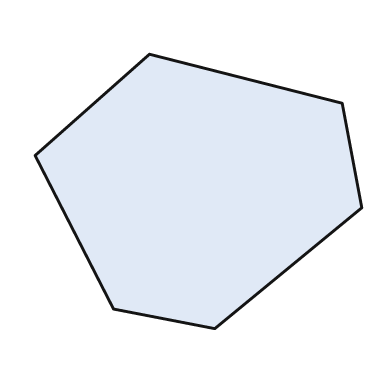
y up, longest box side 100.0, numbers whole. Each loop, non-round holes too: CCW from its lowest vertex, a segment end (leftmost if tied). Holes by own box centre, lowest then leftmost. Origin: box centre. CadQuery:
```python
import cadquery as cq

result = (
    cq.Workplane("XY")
    .moveTo(5.0, -42.0)
    .lineTo(50.0, -5.0)
    .lineTo(44.0, 27.0)
    .lineTo(-15.0, 42.0)
    .lineTo(-50.0, 11.0)
    .lineTo(-26.0, -36.0)
    .close()
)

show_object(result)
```